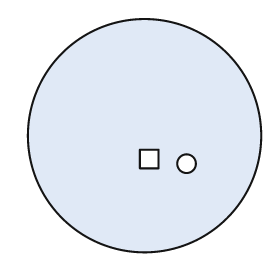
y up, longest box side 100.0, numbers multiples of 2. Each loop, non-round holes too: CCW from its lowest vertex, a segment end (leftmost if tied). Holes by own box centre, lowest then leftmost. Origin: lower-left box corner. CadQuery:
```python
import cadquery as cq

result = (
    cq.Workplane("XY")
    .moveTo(50.0, 50.0)
    .circle(50.0)
    .moveTo(68.0, 38.0)
    .circle(4.0)
    .moveTo(48.0, 36.0)
    .lineTo(56.0, 36.0)
    .lineTo(56.0, 44.0)
    .lineTo(48.0, 44.0)
    .close()
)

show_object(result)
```